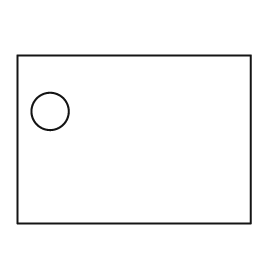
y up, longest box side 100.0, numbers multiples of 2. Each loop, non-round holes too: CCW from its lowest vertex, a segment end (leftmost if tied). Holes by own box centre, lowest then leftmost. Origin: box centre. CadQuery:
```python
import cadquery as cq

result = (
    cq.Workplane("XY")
    .moveTo(-50.0, -36.0)
    .lineTo(50.0, -36.0)
    .lineTo(50.0, 36.0)
    .lineTo(-50.0, 36.0)
    .close()
    .moveTo(-36.0, 12.0)
    .circle(8.0)
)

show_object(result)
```